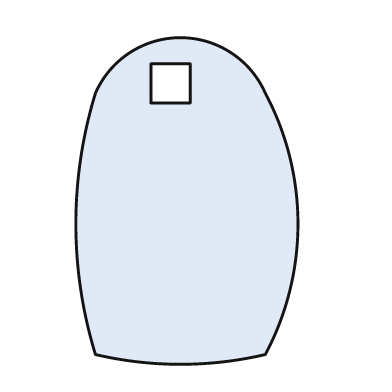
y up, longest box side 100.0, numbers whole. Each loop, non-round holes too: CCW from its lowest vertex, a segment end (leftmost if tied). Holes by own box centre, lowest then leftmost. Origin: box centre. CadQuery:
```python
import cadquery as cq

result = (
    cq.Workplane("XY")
    .moveTo(-28.0, -47.0)
    .threePointArc((-2.0, -50.0), (24.0, -47.0))
    .threePointArc((34.0, -7.0), (24.0, 33.0))
    .threePointArc((-2.0, 50.0), (-28.0, 33.0))
    .threePointArc((-34.0, -7.0), (-28.0, -47.0))
    .close()
    .moveTo(-11.0, 30.0)
    .lineTo(1.0, 30.0)
    .lineTo(1.0, 42.0)
    .lineTo(-11.0, 42.0)
    .close()
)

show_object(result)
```